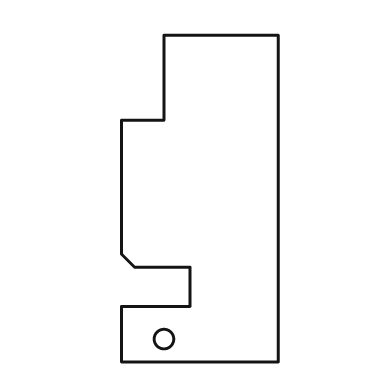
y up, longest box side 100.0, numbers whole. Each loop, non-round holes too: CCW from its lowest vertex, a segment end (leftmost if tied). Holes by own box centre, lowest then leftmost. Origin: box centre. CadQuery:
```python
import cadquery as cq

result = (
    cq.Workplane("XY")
    .moveTo(-24.0, -50.0)
    .lineTo(24.0, -50.0)
    .lineTo(24.0, 50.0)
    .lineTo(-11.0, 50.0)
    .lineTo(-11.0, 24.0)
    .lineTo(-24.0, 24.0)
    .lineTo(-24.0, -17.0)
    .lineTo(-20.0, -21.0)
    .lineTo(-3.0, -21.0)
    .lineTo(-3.0, -33.0)
    .lineTo(-24.0, -33.0)
    .close()
    .moveTo(-11.0, -43.0)
    .circle(3.0)
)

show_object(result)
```